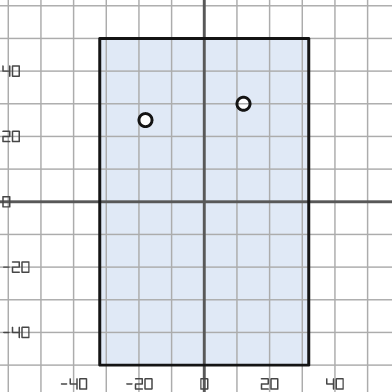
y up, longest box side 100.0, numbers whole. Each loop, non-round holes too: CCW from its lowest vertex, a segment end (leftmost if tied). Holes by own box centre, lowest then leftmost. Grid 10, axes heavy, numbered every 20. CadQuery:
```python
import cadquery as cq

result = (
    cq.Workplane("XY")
    .moveTo(-32.0, -50.0)
    .lineTo(32.0, -50.0)
    .lineTo(32.0, 50.0)
    .lineTo(-32.0, 50.0)
    .close()
    .moveTo(-18.0, 25.0)
    .circle(2.0)
    .moveTo(12.0, 30.0)
    .circle(2.0)
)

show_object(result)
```